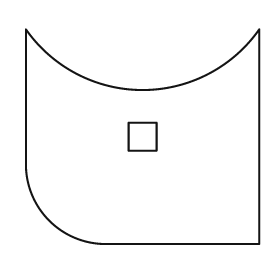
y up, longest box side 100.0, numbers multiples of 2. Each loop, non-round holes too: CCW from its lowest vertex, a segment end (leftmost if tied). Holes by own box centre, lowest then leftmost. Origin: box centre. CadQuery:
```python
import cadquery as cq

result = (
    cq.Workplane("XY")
    .moveTo(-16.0, -46.0)
    .lineTo(50.0, -46.0)
    .lineTo(50.0, 46.0)
    .threePointArc((0.0, 20.0), (-50.0, 46.0))
    .lineTo(-50.0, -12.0)
    .threePointArc((-40.0, -36.0), (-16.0, -46.0))
    .close()
    .moveTo(-6.0, -6.0)
    .lineTo(6.0, -6.0)
    .lineTo(6.0, 6.0)
    .lineTo(-6.0, 6.0)
    .close()
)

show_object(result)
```